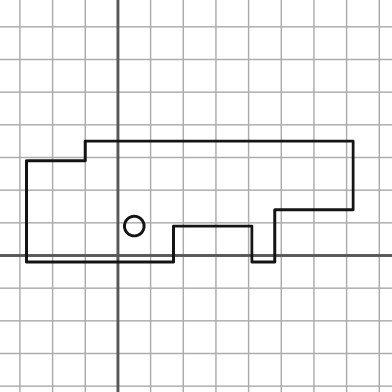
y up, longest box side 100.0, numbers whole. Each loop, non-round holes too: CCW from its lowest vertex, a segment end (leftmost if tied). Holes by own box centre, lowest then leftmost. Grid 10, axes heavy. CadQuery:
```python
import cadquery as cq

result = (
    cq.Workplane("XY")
    .moveTo(-28.0, -2.0)
    .lineTo(17.0, -2.0)
    .lineTo(17.0, 9.0)
    .lineTo(41.0, 9.0)
    .lineTo(41.0, -2.0)
    .lineTo(48.0, -2.0)
    .lineTo(48.0, 14.0)
    .lineTo(72.0, 14.0)
    .lineTo(72.0, 35.0)
    .lineTo(-10.0, 35.0)
    .lineTo(-10.0, 29.0)
    .lineTo(-28.0, 29.0)
    .close()
    .moveTo(5.0, 9.0)
    .circle(3.0)
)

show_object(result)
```